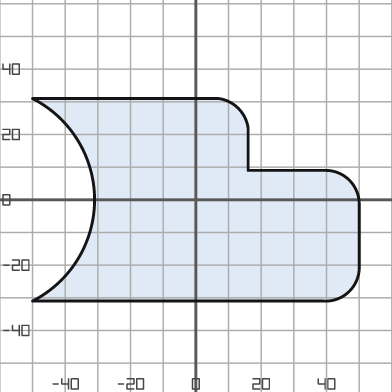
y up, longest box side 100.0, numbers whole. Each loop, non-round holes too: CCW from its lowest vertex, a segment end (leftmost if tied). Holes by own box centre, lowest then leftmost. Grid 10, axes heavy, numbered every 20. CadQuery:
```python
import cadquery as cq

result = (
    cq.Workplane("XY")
    .moveTo(-50.0, -31.0)
    .lineTo(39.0, -31.0)
    .threePointArc((47.0, -28.0), (50.0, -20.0))
    .lineTo(50.0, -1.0)
    .threePointArc((47.0, 6.0), (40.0, 9.0))
    .lineTo(16.0, 9.0)
    .lineTo(16.0, 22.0)
    .threePointArc((13.0, 28.0), (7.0, 31.0))
    .lineTo(-50.0, 31.0)
    .threePointArc((-31.0, 0.0), (-50.0, -31.0))
    .close()
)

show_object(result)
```